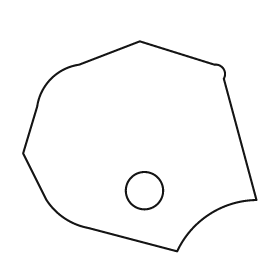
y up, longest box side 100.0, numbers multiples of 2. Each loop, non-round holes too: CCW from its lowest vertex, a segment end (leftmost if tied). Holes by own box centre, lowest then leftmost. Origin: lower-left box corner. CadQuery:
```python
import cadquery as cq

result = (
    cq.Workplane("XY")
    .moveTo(66.0, 0.0)
    .threePointArc((80.0, 16.0), (100.0, 22.0))
    .lineTo(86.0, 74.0)
    .threePointArc((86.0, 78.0), (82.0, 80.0))
    .lineTo(50.0, 90.0)
    .lineTo(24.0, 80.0)
    .threePointArc((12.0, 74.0), (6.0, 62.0))
    .lineTo(0.0, 42.0)
    .lineTo(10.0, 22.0)
    .threePointArc((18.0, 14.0), (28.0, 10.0))
    .close()
    .moveTo(52.0, 26.0)
    .circle(8.0)
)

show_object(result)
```